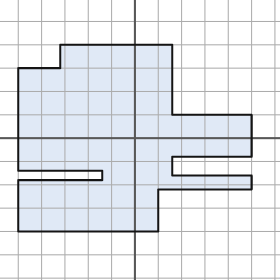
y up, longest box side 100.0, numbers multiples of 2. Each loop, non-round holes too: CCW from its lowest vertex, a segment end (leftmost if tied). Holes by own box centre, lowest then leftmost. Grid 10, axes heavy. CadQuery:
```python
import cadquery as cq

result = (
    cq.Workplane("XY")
    .moveTo(-50.0, -40.0)
    .lineTo(10.0, -40.0)
    .lineTo(10.0, -22.0)
    .lineTo(50.0, -22.0)
    .lineTo(50.0, -16.0)
    .lineTo(16.0, -16.0)
    .lineTo(16.0, -8.0)
    .lineTo(50.0, -8.0)
    .lineTo(50.0, 10.0)
    .lineTo(16.0, 10.0)
    .lineTo(16.0, 40.0)
    .lineTo(-32.0, 40.0)
    .lineTo(-32.0, 30.0)
    .lineTo(-50.0, 30.0)
    .lineTo(-50.0, -14.0)
    .lineTo(-14.0, -14.0)
    .lineTo(-14.0, -18.0)
    .lineTo(-50.0, -18.0)
    .close()
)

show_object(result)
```